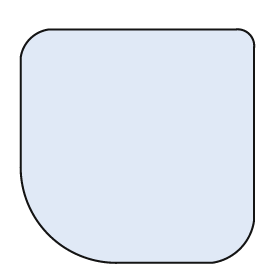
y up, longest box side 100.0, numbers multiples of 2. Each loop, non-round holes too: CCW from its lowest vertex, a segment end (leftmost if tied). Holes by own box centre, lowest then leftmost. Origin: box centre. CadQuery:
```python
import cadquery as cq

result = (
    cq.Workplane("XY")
    .moveTo(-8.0, -50.0)
    .lineTo(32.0, -50.0)
    .threePointArc((44.0, -44.0), (50.0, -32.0))
    .lineTo(50.0, 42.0)
    .threePointArc((48.0, 48.0), (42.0, 50.0))
    .lineTo(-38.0, 50.0)
    .threePointArc((-46.0, 46.0), (-50.0, 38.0))
    .lineTo(-50.0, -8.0)
    .threePointArc((-38.0, -38.0), (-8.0, -50.0))
    .close()
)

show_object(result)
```